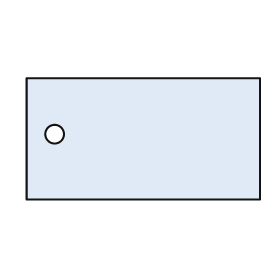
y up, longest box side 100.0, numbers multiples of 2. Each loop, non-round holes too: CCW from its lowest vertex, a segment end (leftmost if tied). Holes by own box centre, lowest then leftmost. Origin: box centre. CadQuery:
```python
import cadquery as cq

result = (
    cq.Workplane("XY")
    .moveTo(-50.0, -26.0)
    .lineTo(50.0, -26.0)
    .lineTo(50.0, 26.0)
    .lineTo(-50.0, 26.0)
    .close()
    .moveTo(-38.0, 2.0)
    .circle(4.0)
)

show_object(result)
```